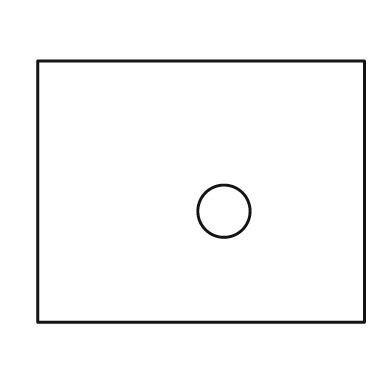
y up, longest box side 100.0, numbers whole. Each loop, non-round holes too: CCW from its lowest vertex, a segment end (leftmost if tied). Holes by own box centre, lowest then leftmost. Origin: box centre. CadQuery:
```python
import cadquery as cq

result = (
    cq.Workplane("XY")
    .moveTo(-50.0, -40.0)
    .lineTo(50.0, -40.0)
    .lineTo(50.0, 40.0)
    .lineTo(-50.0, 40.0)
    .close()
    .moveTo(7.0, -6.0)
    .circle(8.0)
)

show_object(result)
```